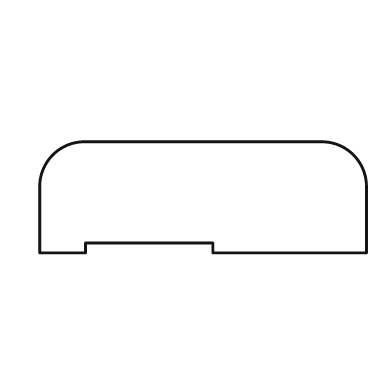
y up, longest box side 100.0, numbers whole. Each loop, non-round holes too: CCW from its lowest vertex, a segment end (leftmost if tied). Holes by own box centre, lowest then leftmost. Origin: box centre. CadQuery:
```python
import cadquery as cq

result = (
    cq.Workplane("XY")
    .moveTo(-50.0, -17.0)
    .lineTo(-36.0, -17.0)
    .lineTo(-36.0, -14.0)
    .lineTo(3.0, -14.0)
    .lineTo(3.0, -17.0)
    .lineTo(50.0, -17.0)
    .lineTo(50.0, 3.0)
    .threePointArc((46.0, 13.0), (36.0, 17.0))
    .lineTo(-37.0, 17.0)
    .threePointArc((-46.0, 13.0), (-50.0, 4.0))
    .close()
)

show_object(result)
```